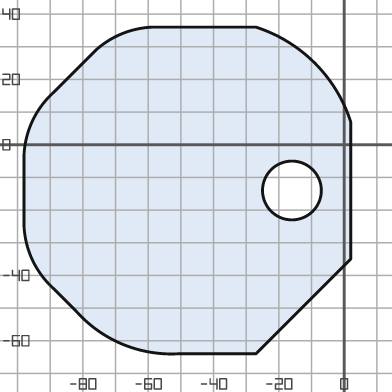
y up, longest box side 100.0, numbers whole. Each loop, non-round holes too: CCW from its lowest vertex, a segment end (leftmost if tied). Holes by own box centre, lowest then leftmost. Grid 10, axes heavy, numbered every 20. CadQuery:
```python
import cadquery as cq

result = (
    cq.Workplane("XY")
    .moveTo(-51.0, -64.0)
    .lineTo(-27.0, -64.0)
    .lineTo(2.0, -35.0)
    .lineTo(2.0, 7.0)
    .threePointArc((-9.0, 25.0), (-27.0, 36.0))
    .lineTo(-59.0, 36.0)
    .threePointArc((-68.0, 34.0), (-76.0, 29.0))
    .lineTo(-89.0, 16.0)
    .threePointArc((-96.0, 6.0), (-98.0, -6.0))
    .lineTo(-98.0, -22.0)
    .threePointArc((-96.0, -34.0), (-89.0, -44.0))
    .lineTo(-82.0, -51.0)
    .threePointArc((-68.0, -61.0), (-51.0, -64.0))
    .close()
    .moveTo(-16.0, -14.0)
    .circle(9.0)
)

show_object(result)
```